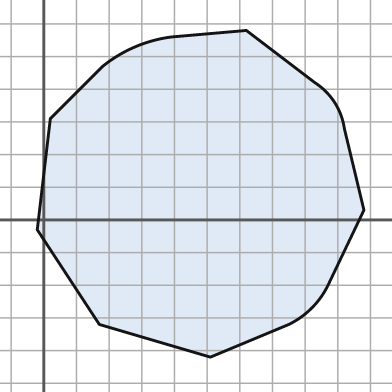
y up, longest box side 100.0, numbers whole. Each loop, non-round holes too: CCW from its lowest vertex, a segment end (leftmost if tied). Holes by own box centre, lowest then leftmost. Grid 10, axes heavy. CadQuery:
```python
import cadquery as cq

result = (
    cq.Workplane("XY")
    .moveTo(51.0, -42.0)
    .lineTo(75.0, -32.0)
    .threePointArc((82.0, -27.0), (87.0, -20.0))
    .lineTo(98.0, 3.0)
    .lineTo(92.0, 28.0)
    .threePointArc((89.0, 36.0), (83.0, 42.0))
    .lineTo(62.0, 58.0)
    .lineTo(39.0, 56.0)
    .threePointArc((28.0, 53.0), (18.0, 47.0))
    .lineTo(2.0, 31.0)
    .lineTo(-2.0, -3.0)
    .lineTo(17.0, -32.0)
    .close()
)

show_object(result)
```